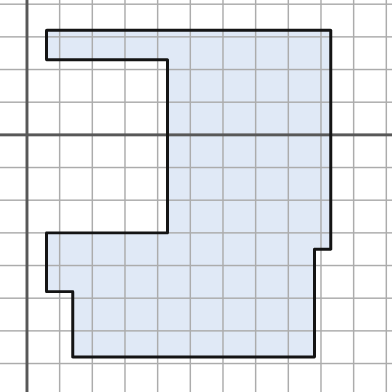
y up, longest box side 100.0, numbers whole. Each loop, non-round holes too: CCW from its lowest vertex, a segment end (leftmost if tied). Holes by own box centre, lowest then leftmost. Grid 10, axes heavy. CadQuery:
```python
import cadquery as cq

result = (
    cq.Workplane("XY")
    .moveTo(14.0, -68.0)
    .lineTo(88.0, -68.0)
    .lineTo(88.0, -35.0)
    .lineTo(93.0, -35.0)
    .lineTo(93.0, 32.0)
    .lineTo(6.0, 32.0)
    .lineTo(6.0, 23.0)
    .lineTo(43.0, 23.0)
    .lineTo(43.0, -30.0)
    .lineTo(6.0, -30.0)
    .lineTo(6.0, -48.0)
    .lineTo(14.0, -48.0)
    .close()
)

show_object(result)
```